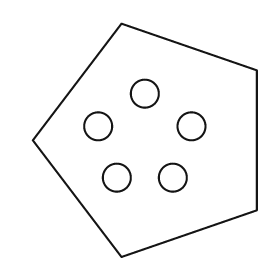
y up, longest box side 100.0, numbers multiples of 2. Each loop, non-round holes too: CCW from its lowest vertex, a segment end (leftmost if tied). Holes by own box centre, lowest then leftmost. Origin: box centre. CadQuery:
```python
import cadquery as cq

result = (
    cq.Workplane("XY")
    .moveTo(-10.0, -50.0)
    .lineTo(48.0, -30.0)
    .lineTo(48.0, 30.0)
    .lineTo(-10.0, 50.0)
    .lineTo(-48.0, 0.0)
    .close()
    .moveTo(-12.0, -16.0)
    .circle(6.0)
    .moveTo(12.0, -16.0)
    .circle(6.0)
    .moveTo(-20.0, 6.0)
    .circle(6.0)
    .moveTo(20.0, 6.0)
    .circle(6.0)
    .moveTo(0.0, 20.0)
    .circle(6.0)
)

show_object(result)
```